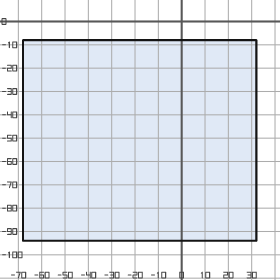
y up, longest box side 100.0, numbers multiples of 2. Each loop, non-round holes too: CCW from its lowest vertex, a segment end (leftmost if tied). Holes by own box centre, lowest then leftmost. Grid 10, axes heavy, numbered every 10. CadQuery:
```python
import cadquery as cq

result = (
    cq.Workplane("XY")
    .moveTo(-68.0, -94.0)
    .lineTo(32.0, -94.0)
    .lineTo(32.0, -8.0)
    .lineTo(-68.0, -8.0)
    .close()
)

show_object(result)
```